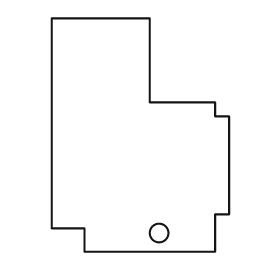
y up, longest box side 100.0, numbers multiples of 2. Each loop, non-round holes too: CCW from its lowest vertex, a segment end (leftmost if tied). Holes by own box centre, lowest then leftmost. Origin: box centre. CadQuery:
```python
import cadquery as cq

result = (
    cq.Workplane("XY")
    .moveTo(-24.0, -50.0)
    .lineTo(32.0, -50.0)
    .lineTo(32.0, -34.0)
    .lineTo(38.0, -34.0)
    .lineTo(38.0, 8.0)
    .lineTo(32.0, 8.0)
    .lineTo(32.0, 14.0)
    .lineTo(4.0, 14.0)
    .lineTo(4.0, 50.0)
    .lineTo(-38.0, 50.0)
    .lineTo(-38.0, -40.0)
    .lineTo(-24.0, -40.0)
    .close()
    .moveTo(8.0, -42.0)
    .circle(4.0)
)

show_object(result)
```